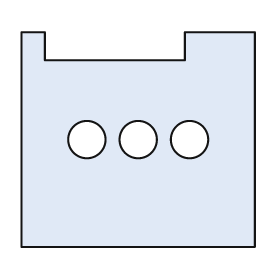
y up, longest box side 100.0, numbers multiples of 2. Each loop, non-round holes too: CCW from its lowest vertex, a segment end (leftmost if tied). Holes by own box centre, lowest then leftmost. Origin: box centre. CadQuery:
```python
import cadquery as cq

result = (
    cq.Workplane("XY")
    .moveTo(-50.0, -46.0)
    .lineTo(50.0, -46.0)
    .lineTo(50.0, 46.0)
    .lineTo(20.0, 46.0)
    .lineTo(20.0, 34.0)
    .lineTo(-40.0, 34.0)
    .lineTo(-40.0, 46.0)
    .lineTo(-50.0, 46.0)
    .close()
    .moveTo(-22.0, 0.0)
    .circle(8.0)
    .moveTo(0.0, 0.0)
    .circle(8.0)
    .moveTo(22.0, 0.0)
    .circle(8.0)
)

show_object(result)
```